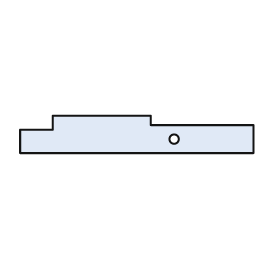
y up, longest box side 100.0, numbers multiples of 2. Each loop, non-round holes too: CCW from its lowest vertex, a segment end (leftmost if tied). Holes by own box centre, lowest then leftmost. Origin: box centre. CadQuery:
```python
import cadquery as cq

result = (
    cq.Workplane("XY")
    .moveTo(-50.0, -8.0)
    .lineTo(50.0, -8.0)
    .lineTo(50.0, 4.0)
    .lineTo(6.0, 4.0)
    .lineTo(6.0, 8.0)
    .lineTo(-36.0, 8.0)
    .lineTo(-36.0, 2.0)
    .lineTo(-50.0, 2.0)
    .close()
    .moveTo(16.0, -2.0)
    .circle(2.0)
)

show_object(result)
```